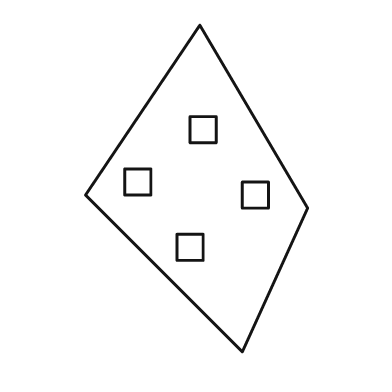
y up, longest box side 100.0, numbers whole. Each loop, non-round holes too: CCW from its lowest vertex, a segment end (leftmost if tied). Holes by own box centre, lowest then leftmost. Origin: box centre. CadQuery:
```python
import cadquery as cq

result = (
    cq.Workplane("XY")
    .moveTo(14.0, -50.0)
    .lineTo(34.0, -6.0)
    .lineTo(1.0, 50.0)
    .lineTo(-34.0, -2.0)
    .close()
    .moveTo(-6.0, -22.0)
    .lineTo(2.0, -22.0)
    .lineTo(2.0, -14.0)
    .lineTo(-6.0, -14.0)
    .close()
    .moveTo(14.0, -6.0)
    .lineTo(22.0, -6.0)
    .lineTo(22.0, 2.0)
    .lineTo(14.0, 2.0)
    .close()
    .moveTo(-22.0, -2.0)
    .lineTo(-14.0, -2.0)
    .lineTo(-14.0, 6.0)
    .lineTo(-22.0, 6.0)
    .close()
    .moveTo(-2.0, 14.0)
    .lineTo(6.0, 14.0)
    .lineTo(6.0, 22.0)
    .lineTo(-2.0, 22.0)
    .close()
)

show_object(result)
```